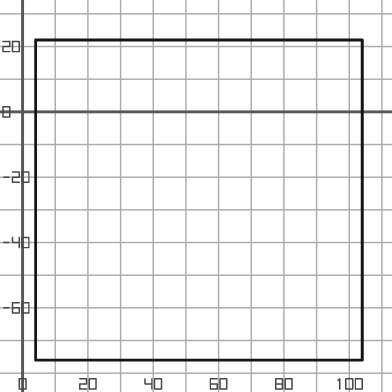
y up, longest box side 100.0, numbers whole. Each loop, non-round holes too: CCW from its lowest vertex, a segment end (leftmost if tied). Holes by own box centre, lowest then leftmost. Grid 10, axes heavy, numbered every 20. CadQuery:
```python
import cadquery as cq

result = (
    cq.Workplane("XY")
    .moveTo(4.0, -76.0)
    .lineTo(104.0, -76.0)
    .lineTo(104.0, 22.0)
    .lineTo(4.0, 22.0)
    .close()
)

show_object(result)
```